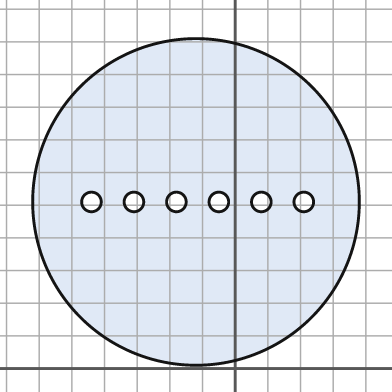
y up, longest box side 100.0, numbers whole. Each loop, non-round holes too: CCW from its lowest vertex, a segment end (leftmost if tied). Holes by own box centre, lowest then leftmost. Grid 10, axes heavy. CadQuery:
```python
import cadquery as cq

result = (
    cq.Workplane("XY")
    .moveTo(-12.0, 51.0)
    .circle(50.0)
    .moveTo(-44.0, 51.0)
    .circle(3.0)
    .moveTo(-31.0, 51.0)
    .circle(3.0)
    .moveTo(-18.0, 51.0)
    .circle(3.0)
    .moveTo(-5.0, 51.0)
    .circle(3.0)
    .moveTo(8.0, 51.0)
    .circle(3.0)
    .moveTo(21.0, 51.0)
    .circle(3.0)
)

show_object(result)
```